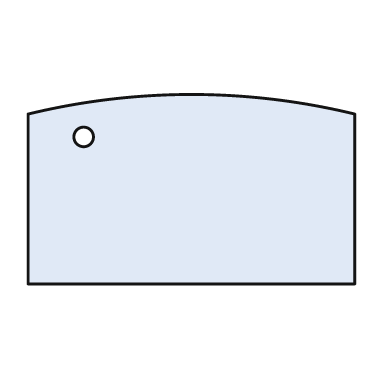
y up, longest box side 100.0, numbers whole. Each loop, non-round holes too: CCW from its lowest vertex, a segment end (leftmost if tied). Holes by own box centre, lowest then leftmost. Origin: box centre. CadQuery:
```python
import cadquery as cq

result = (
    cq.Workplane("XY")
    .moveTo(-50.0, -29.0)
    .lineTo(50.0, -29.0)
    .lineTo(50.0, 23.0)
    .threePointArc((0.0, 29.0), (-50.0, 23.0))
    .close()
    .moveTo(-33.0, 16.0)
    .circle(3.0)
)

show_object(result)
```